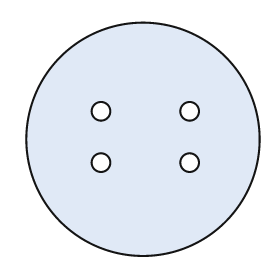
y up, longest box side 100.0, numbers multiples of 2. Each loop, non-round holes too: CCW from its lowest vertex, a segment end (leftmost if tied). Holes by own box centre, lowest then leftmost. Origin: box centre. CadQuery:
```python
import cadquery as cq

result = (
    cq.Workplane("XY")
    .moveTo(0.0, 0.0)
    .circle(50.0)
    .moveTo(-18.0, -10.0)
    .circle(4.0)
    .moveTo(20.0, -10.0)
    .circle(4.0)
    .moveTo(-18.0, 12.0)
    .circle(4.0)
    .moveTo(20.0, 12.0)
    .circle(4.0)
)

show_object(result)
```